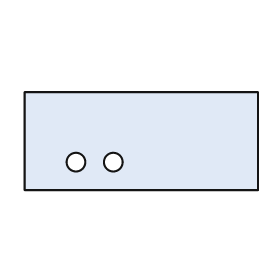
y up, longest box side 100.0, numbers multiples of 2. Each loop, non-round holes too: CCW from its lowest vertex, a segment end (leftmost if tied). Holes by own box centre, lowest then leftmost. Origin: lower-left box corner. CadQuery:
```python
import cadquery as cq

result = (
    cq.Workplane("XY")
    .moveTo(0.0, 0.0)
    .lineTo(100.0, 0.0)
    .lineTo(100.0, 42.0)
    .lineTo(0.0, 42.0)
    .close()
    .moveTo(22.0, 12.0)
    .circle(4.0)
    .moveTo(38.0, 12.0)
    .circle(4.0)
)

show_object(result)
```